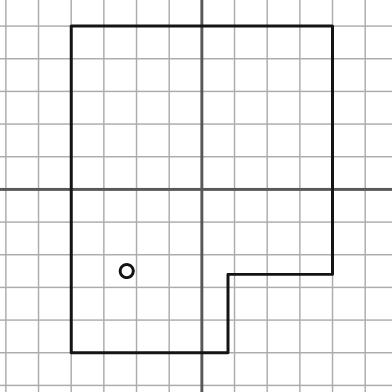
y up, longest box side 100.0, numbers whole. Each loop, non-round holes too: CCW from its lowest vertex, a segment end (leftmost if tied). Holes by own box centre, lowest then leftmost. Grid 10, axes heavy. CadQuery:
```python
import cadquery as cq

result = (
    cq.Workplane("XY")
    .moveTo(-40.0, -50.0)
    .lineTo(8.0, -50.0)
    .lineTo(8.0, -26.0)
    .lineTo(40.0, -26.0)
    .lineTo(40.0, 50.0)
    .lineTo(-40.0, 50.0)
    .close()
    .moveTo(-23.0, -25.0)
    .circle(2.0)
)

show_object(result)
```